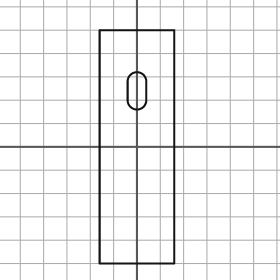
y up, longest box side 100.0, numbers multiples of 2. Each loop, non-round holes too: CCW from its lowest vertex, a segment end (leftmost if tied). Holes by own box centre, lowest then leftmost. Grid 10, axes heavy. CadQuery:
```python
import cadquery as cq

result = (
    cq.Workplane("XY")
    .moveTo(-16.0, -50.0)
    .lineTo(16.0, -50.0)
    .lineTo(16.0, 50.0)
    .lineTo(-16.0, 50.0)
    .close()
    .moveTo(-4.0, 20.0)
    .threePointArc((0.0, 16.0), (4.0, 20.0))
    .lineTo(4.0, 28.0)
    .threePointArc((0.0, 32.0), (-4.0, 28.0))
    .close()
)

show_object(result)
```